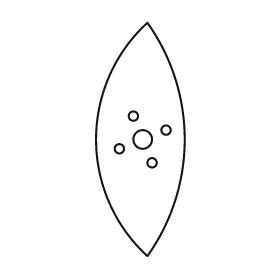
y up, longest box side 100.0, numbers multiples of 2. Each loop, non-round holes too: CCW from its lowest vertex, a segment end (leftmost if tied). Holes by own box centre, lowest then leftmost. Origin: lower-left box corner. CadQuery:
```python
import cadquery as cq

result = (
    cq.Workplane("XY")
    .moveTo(22.0, 0.0)
    .threePointArc((38.0, 50.0), (22.0, 100.0))
    .threePointArc((0.0, 50.0), (22.0, 0.0))
    .close()
    .moveTo(24.0, 40.0)
    .circle(2.0)
    .moveTo(10.0, 46.0)
    .circle(2.0)
    .moveTo(20.0, 50.0)
    .circle(4.0)
    .moveTo(30.0, 54.0)
    .circle(2.0)
    .moveTo(16.0, 60.0)
    .circle(2.0)
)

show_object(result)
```